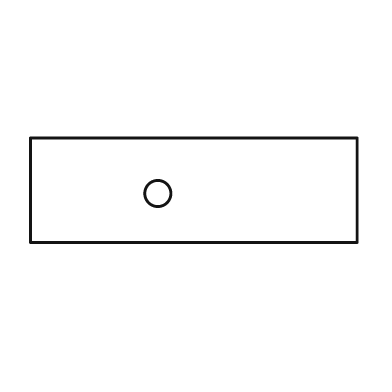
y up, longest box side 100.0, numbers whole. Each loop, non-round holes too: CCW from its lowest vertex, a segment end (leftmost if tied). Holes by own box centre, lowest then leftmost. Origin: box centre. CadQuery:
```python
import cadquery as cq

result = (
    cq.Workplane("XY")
    .moveTo(-50.0, -16.0)
    .lineTo(50.0, -16.0)
    .lineTo(50.0, 16.0)
    .lineTo(-50.0, 16.0)
    .close()
    .moveTo(-11.0, -1.0)
    .circle(4.0)
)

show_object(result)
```